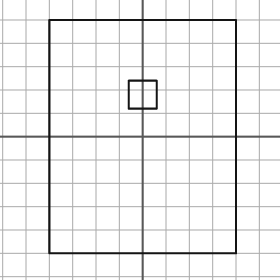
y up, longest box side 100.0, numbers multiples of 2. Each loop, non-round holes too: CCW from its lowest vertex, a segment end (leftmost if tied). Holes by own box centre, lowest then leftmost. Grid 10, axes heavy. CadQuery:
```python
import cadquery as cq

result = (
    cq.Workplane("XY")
    .moveTo(-40.0, -50.0)
    .lineTo(40.0, -50.0)
    .lineTo(40.0, 50.0)
    .lineTo(-40.0, 50.0)
    .close()
    .moveTo(-6.0, 12.0)
    .lineTo(6.0, 12.0)
    .lineTo(6.0, 24.0)
    .lineTo(-6.0, 24.0)
    .close()
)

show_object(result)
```